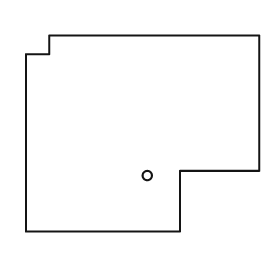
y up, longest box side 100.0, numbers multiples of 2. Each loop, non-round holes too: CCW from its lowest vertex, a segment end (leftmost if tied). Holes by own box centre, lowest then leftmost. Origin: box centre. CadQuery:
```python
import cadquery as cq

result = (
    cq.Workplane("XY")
    .moveTo(-50.0, -42.0)
    .lineTo(16.0, -42.0)
    .lineTo(16.0, -16.0)
    .lineTo(50.0, -16.0)
    .lineTo(50.0, 42.0)
    .lineTo(-40.0, 42.0)
    .lineTo(-40.0, 34.0)
    .lineTo(-50.0, 34.0)
    .close()
    .moveTo(2.0, -18.0)
    .circle(2.0)
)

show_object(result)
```